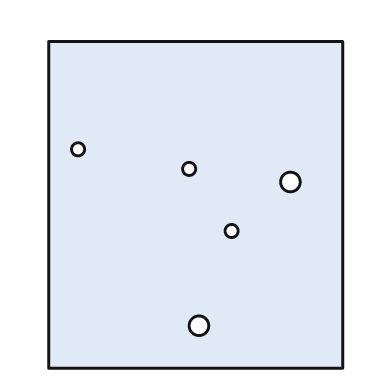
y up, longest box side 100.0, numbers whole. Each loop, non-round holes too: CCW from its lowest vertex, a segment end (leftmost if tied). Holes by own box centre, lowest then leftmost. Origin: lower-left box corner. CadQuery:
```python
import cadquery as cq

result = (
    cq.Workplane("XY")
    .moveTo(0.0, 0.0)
    .lineTo(90.0, 0.0)
    .lineTo(90.0, 100.0)
    .lineTo(0.0, 100.0)
    .close()
    .moveTo(46.0, 13.0)
    .circle(3.0)
    .moveTo(56.0, 42.0)
    .circle(2.0)
    .moveTo(74.0, 57.0)
    .circle(3.0)
    .moveTo(43.0, 61.0)
    .circle(2.0)
    .moveTo(9.0, 67.0)
    .circle(2.0)
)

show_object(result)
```